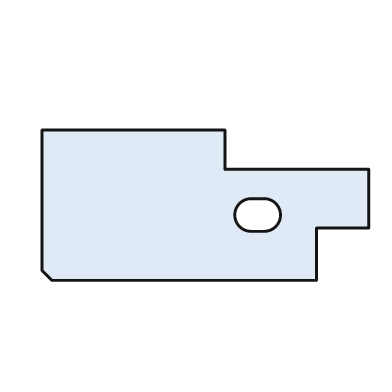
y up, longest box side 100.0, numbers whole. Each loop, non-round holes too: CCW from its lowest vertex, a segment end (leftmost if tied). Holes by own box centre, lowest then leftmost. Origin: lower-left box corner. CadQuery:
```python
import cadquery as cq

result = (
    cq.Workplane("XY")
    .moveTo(3.0, 0.0)
    .lineTo(84.0, 0.0)
    .lineTo(84.0, 16.0)
    .lineTo(100.0, 16.0)
    .lineTo(100.0, 34.0)
    .lineTo(56.0, 34.0)
    .lineTo(56.0, 46.0)
    .lineTo(0.0, 46.0)
    .lineTo(0.0, 3.0)
    .close()
    .moveTo(64.0, 15.0)
    .lineTo(68.0, 15.0)
    .threePointArc((73.0, 20.0), (68.0, 25.0))
    .lineTo(64.0, 25.0)
    .threePointArc((59.0, 20.0), (64.0, 15.0))
    .close()
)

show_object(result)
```